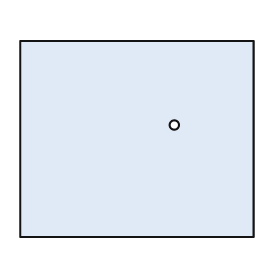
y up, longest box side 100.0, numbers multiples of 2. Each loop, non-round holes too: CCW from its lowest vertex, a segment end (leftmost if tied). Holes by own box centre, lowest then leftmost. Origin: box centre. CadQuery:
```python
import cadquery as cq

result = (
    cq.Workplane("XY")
    .moveTo(-50.0, -42.0)
    .lineTo(50.0, -42.0)
    .lineTo(50.0, 42.0)
    .lineTo(-50.0, 42.0)
    .close()
    .moveTo(16.0, 6.0)
    .circle(2.0)
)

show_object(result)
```